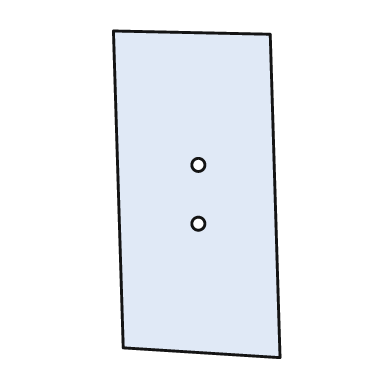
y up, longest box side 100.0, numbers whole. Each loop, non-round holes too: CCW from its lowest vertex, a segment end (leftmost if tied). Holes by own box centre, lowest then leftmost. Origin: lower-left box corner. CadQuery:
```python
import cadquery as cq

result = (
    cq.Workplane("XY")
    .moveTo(51.0, 0.0)
    .lineTo(48.0, 99.0)
    .lineTo(0.0, 100.0)
    .lineTo(3.0, 3.0)
    .close()
    .moveTo(26.0, 41.0)
    .circle(2.0)
    .moveTo(26.0, 59.0)
    .circle(2.0)
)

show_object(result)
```